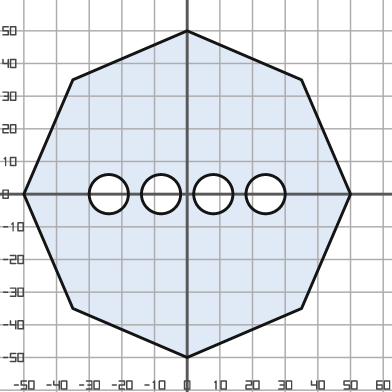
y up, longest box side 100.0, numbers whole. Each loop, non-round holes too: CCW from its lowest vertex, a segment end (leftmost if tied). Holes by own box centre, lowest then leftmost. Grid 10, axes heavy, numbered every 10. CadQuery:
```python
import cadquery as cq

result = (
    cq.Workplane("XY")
    .moveTo(0.0, -50.0)
    .lineTo(35.0, -35.0)
    .lineTo(50.0, 0.0)
    .lineTo(35.0, 35.0)
    .lineTo(0.0, 50.0)
    .lineTo(-35.0, 35.0)
    .lineTo(-50.0, 0.0)
    .lineTo(-35.0, -35.0)
    .close()
    .moveTo(-24.0, 0.0)
    .circle(6.0)
    .moveTo(-8.0, 0.0)
    .circle(6.0)
    .moveTo(8.0, 0.0)
    .circle(6.0)
    .moveTo(24.0, 0.0)
    .circle(6.0)
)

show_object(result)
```